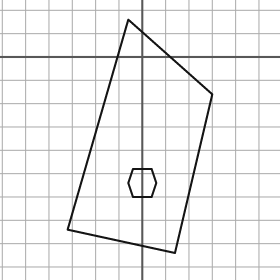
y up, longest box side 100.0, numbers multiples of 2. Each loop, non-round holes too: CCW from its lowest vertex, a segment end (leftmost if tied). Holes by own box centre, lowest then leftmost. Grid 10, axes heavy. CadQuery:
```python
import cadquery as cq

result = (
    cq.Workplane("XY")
    .moveTo(14.0, -84.0)
    .lineTo(30.0, -16.0)
    .lineTo(-6.0, 16.0)
    .lineTo(-32.0, -74.0)
    .close()
    .moveTo(-4.0, -60.0)
    .lineTo(4.0, -60.0)
    .lineTo(6.0, -54.0)
    .lineTo(4.0, -48.0)
    .lineTo(-4.0, -48.0)
    .lineTo(-6.0, -54.0)
    .close()
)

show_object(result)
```